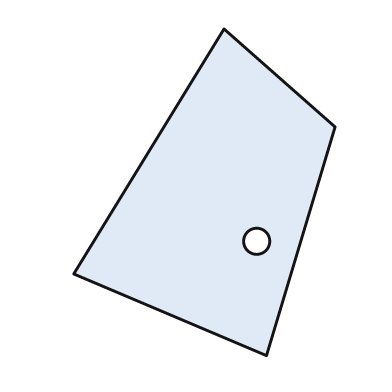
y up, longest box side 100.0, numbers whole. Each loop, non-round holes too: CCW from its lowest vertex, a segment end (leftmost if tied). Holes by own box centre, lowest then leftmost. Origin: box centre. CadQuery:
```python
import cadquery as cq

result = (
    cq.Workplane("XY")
    .moveTo(19.0, -50.0)
    .lineTo(40.0, 20.0)
    .lineTo(6.0, 50.0)
    .lineTo(-40.0, -25.0)
    .close()
    .moveTo(16.0, -15.0)
    .circle(4.0)
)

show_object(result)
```